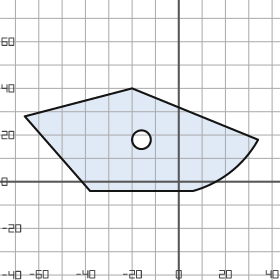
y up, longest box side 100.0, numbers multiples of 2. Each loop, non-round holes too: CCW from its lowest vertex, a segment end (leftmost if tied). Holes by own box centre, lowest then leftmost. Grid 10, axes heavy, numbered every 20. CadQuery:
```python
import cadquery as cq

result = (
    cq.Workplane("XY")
    .moveTo(-38.0, -4.0)
    .lineTo(6.0, -4.0)
    .threePointArc((22.0, 4.0), (34.0, 18.0))
    .lineTo(-20.0, 40.0)
    .lineTo(-66.0, 28.0)
    .close()
    .moveTo(-16.0, 18.0)
    .circle(4.0)
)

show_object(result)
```